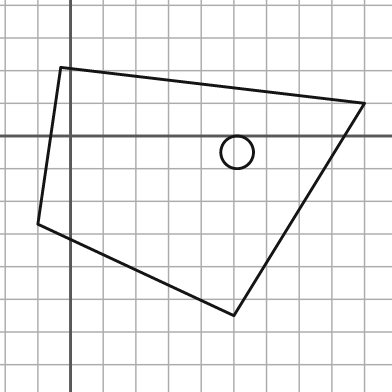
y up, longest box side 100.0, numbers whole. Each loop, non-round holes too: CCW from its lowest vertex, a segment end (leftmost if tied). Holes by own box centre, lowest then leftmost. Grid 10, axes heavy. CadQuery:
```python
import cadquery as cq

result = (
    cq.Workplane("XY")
    .moveTo(50.0, -55.0)
    .lineTo(90.0, 10.0)
    .lineTo(-3.0, 21.0)
    .lineTo(-10.0, -27.0)
    .close()
    .moveTo(51.0, -5.0)
    .circle(5.0)
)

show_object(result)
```